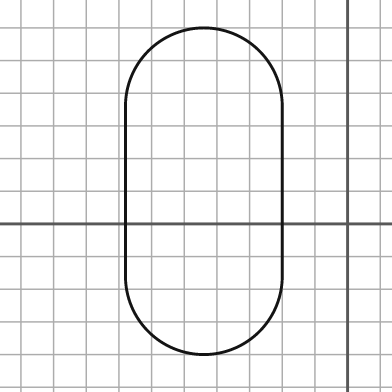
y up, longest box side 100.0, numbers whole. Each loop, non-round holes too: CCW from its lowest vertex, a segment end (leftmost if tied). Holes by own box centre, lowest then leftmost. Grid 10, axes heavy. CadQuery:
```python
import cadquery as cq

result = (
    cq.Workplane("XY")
    .moveTo(-68.0, -16.0)
    .threePointArc((-44.0, -40.0), (-20.0, -16.0))
    .lineTo(-20.0, 36.0)
    .threePointArc((-44.0, 60.0), (-68.0, 36.0))
    .close()
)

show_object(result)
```